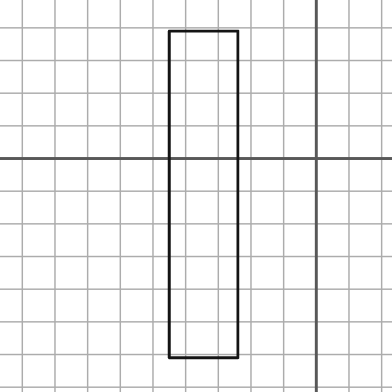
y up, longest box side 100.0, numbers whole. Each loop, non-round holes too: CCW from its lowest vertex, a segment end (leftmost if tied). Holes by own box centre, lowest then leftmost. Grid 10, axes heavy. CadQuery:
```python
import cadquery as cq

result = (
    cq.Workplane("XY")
    .moveTo(-45.0, -61.0)
    .lineTo(-24.0, -61.0)
    .lineTo(-24.0, 39.0)
    .lineTo(-45.0, 39.0)
    .close()
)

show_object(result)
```